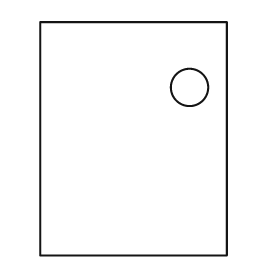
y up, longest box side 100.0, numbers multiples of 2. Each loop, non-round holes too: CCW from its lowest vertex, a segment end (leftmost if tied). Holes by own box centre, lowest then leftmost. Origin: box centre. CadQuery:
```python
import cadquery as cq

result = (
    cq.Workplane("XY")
    .moveTo(-40.0, -50.0)
    .lineTo(40.0, -50.0)
    .lineTo(40.0, 50.0)
    .lineTo(-40.0, 50.0)
    .close()
    .moveTo(24.0, 22.0)
    .circle(8.0)
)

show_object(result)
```